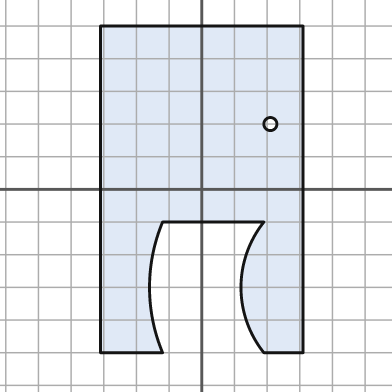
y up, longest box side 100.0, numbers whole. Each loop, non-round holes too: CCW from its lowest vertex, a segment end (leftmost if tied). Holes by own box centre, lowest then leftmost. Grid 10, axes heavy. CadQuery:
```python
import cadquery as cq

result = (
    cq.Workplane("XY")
    .moveTo(-31.0, -50.0)
    .lineTo(-12.0, -50.0)
    .threePointArc((-16.0, -30.0), (-12.0, -10.0))
    .lineTo(19.0, -10.0)
    .threePointArc((12.0, -30.0), (19.0, -50.0))
    .lineTo(31.0, -50.0)
    .lineTo(31.0, 50.0)
    .lineTo(-31.0, 50.0)
    .close()
    .moveTo(21.0, 20.0)
    .circle(2.0)
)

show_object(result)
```